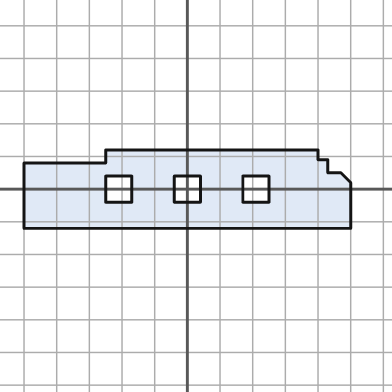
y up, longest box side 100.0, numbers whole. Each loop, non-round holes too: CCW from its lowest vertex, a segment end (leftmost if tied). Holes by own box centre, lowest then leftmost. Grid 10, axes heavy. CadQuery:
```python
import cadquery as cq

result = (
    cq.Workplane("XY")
    .moveTo(-50.0, -12.0)
    .lineTo(50.0, -12.0)
    .lineTo(50.0, 2.0)
    .lineTo(47.0, 5.0)
    .lineTo(43.0, 5.0)
    .lineTo(43.0, 9.0)
    .lineTo(40.0, 9.0)
    .lineTo(40.0, 12.0)
    .lineTo(-25.0, 12.0)
    .lineTo(-25.0, 8.0)
    .lineTo(-50.0, 8.0)
    .close()
    .moveTo(-25.0, -4.0)
    .lineTo(-17.0, -4.0)
    .lineTo(-17.0, 4.0)
    .lineTo(-25.0, 4.0)
    .close()
    .moveTo(-4.0, -4.0)
    .lineTo(4.0, -4.0)
    .lineTo(4.0, 4.0)
    .lineTo(-4.0, 4.0)
    .close()
    .moveTo(17.0, -4.0)
    .lineTo(25.0, -4.0)
    .lineTo(25.0, 4.0)
    .lineTo(17.0, 4.0)
    .close()
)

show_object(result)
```